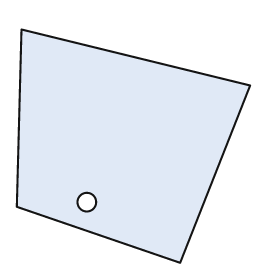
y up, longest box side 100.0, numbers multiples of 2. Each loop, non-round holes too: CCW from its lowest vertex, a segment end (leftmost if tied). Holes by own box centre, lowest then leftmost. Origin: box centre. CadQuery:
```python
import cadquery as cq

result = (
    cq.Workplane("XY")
    .moveTo(20.0, -50.0)
    .lineTo(50.0, 26.0)
    .lineTo(-48.0, 50.0)
    .lineTo(-50.0, -26.0)
    .close()
    .moveTo(-20.0, -24.0)
    .circle(4.0)
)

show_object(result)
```